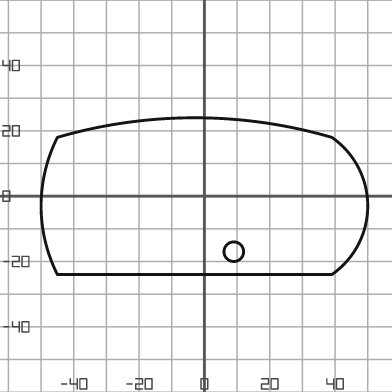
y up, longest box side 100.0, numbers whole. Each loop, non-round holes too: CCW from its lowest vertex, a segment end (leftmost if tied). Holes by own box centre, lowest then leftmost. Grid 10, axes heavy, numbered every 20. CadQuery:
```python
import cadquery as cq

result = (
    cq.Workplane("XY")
    .moveTo(-45.0, -24.0)
    .lineTo(39.0, -24.0)
    .threePointArc((50.0, -3.0), (39.0, 18.0))
    .threePointArc((-3.0, 24.0), (-45.0, 18.0))
    .threePointArc((-50.0, -3.0), (-45.0, -24.0))
    .close()
    .moveTo(9.0, -17.0)
    .circle(3.0)
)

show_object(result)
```